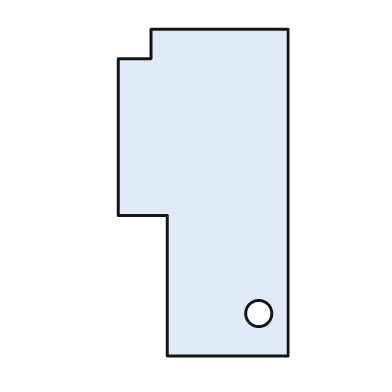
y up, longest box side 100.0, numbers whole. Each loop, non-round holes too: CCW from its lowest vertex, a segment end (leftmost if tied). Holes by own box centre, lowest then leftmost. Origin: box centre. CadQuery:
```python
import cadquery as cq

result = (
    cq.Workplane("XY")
    .moveTo(-11.0, -50.0)
    .lineTo(26.0, -50.0)
    .lineTo(26.0, 50.0)
    .lineTo(-16.0, 50.0)
    .lineTo(-16.0, 41.0)
    .lineTo(-26.0, 41.0)
    .lineTo(-26.0, -7.0)
    .lineTo(-11.0, -7.0)
    .close()
    .moveTo(17.0, -37.0)
    .circle(4.0)
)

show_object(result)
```